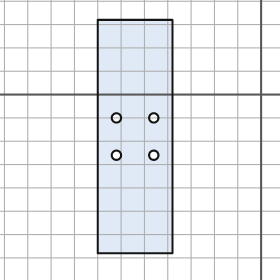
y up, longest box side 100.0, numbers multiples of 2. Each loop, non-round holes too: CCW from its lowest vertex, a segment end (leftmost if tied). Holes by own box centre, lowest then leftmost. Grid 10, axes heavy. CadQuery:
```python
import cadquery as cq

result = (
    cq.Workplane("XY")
    .moveTo(-70.0, -68.0)
    .lineTo(-38.0, -68.0)
    .lineTo(-38.0, 32.0)
    .lineTo(-70.0, 32.0)
    .close()
    .moveTo(-62.0, -26.0)
    .circle(2.0)
    .moveTo(-46.0, -26.0)
    .circle(2.0)
    .moveTo(-62.0, -10.0)
    .circle(2.0)
    .moveTo(-46.0, -10.0)
    .circle(2.0)
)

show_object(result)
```